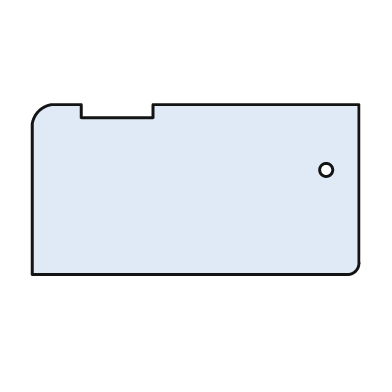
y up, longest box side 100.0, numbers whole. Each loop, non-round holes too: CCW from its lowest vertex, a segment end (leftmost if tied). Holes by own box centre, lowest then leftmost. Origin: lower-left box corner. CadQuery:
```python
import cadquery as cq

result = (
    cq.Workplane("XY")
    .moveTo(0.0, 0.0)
    .lineTo(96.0, 0.0)
    .threePointArc((99.0, 1.0), (100.0, 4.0))
    .lineTo(100.0, 52.0)
    .lineTo(37.0, 52.0)
    .lineTo(37.0, 48.0)
    .lineTo(15.0, 48.0)
    .lineTo(15.0, 52.0)
    .lineTo(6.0, 52.0)
    .threePointArc((2.0, 50.0), (0.0, 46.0))
    .close()
    .moveTo(90.0, 32.0)
    .circle(2.0)
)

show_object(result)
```